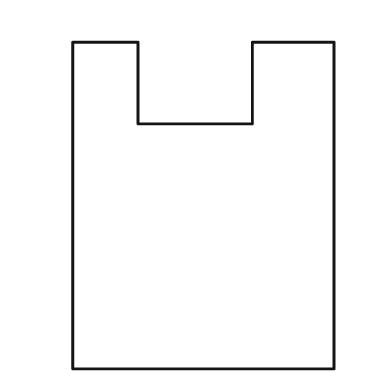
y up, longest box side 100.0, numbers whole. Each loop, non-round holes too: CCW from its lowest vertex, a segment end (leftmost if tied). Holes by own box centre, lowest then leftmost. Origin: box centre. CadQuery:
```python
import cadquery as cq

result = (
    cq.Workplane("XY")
    .moveTo(-40.0, -50.0)
    .lineTo(40.0, -50.0)
    .lineTo(40.0, 50.0)
    .lineTo(15.0, 50.0)
    .lineTo(15.0, 25.0)
    .lineTo(-20.0, 25.0)
    .lineTo(-20.0, 50.0)
    .lineTo(-40.0, 50.0)
    .close()
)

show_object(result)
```